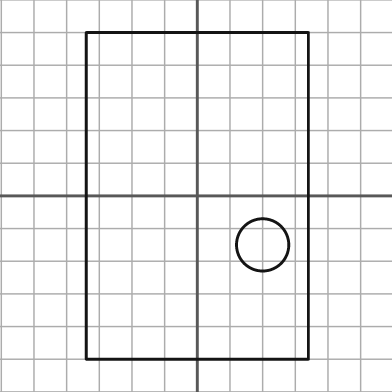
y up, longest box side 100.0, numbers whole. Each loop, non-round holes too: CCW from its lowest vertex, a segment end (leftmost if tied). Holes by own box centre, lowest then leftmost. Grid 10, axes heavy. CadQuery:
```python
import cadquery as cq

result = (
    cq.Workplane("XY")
    .moveTo(-34.0, -50.0)
    .lineTo(34.0, -50.0)
    .lineTo(34.0, 50.0)
    .lineTo(-34.0, 50.0)
    .close()
    .moveTo(20.0, -15.0)
    .circle(8.0)
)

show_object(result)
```